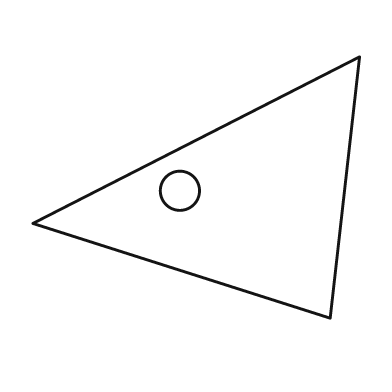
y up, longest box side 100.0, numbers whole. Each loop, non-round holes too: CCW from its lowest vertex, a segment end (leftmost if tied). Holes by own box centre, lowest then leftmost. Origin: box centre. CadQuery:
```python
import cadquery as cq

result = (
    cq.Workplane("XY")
    .moveTo(41.0, -40.0)
    .lineTo(50.0, 40.0)
    .lineTo(-50.0, -11.0)
    .close()
    .moveTo(-5.0, -1.0)
    .circle(6.0)
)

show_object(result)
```